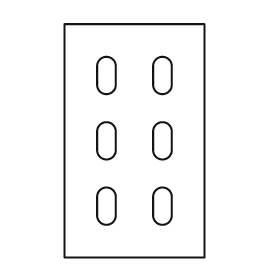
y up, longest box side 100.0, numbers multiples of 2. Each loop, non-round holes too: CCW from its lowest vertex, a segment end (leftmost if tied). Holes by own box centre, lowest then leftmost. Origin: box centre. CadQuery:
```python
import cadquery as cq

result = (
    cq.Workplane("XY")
    .moveTo(-30.0, -50.0)
    .lineTo(30.0, -50.0)
    .lineTo(30.0, 50.0)
    .lineTo(-30.0, 50.0)
    .close()
    .moveTo(-16.0, -32.0)
    .threePointArc((-12.0, -36.0), (-8.0, -32.0))
    .lineTo(-8.0, -24.0)
    .threePointArc((-12.0, -20.0), (-16.0, -24.0))
    .close()
    .moveTo(8.0, -32.0)
    .threePointArc((12.0, -36.0), (16.0, -32.0))
    .lineTo(16.0, -24.0)
    .threePointArc((12.0, -20.0), (8.0, -24.0))
    .close()
    .moveTo(-16.0, -4.0)
    .threePointArc((-12.0, -8.0), (-8.0, -4.0))
    .lineTo(-8.0, 4.0)
    .threePointArc((-12.0, 8.0), (-16.0, 4.0))
    .close()
    .moveTo(8.0, -4.0)
    .threePointArc((12.0, -8.0), (16.0, -4.0))
    .lineTo(16.0, 4.0)
    .threePointArc((12.0, 8.0), (8.0, 4.0))
    .close()
    .moveTo(-16.0, 24.0)
    .threePointArc((-12.0, 20.0), (-8.0, 24.0))
    .lineTo(-8.0, 32.0)
    .threePointArc((-12.0, 36.0), (-16.0, 32.0))
    .close()
    .moveTo(8.0, 24.0)
    .threePointArc((12.0, 20.0), (16.0, 24.0))
    .lineTo(16.0, 32.0)
    .threePointArc((12.0, 36.0), (8.0, 32.0))
    .close()
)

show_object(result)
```